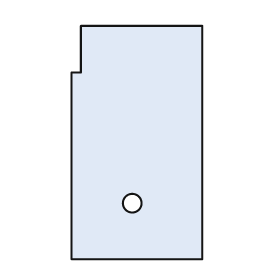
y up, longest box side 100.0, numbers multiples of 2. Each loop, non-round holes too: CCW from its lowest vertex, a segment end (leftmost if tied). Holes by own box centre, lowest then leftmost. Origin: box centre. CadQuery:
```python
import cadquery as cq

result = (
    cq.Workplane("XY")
    .moveTo(-28.0, -50.0)
    .lineTo(28.0, -50.0)
    .lineTo(28.0, 50.0)
    .lineTo(-24.0, 50.0)
    .lineTo(-24.0, 30.0)
    .lineTo(-28.0, 30.0)
    .close()
    .moveTo(-2.0, -26.0)
    .circle(4.0)
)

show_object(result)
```